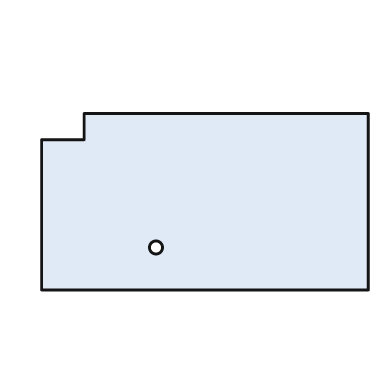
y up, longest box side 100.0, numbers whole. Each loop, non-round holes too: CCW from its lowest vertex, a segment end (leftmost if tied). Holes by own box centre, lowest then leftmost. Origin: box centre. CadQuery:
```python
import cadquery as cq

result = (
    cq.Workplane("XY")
    .moveTo(-50.0, -27.0)
    .lineTo(50.0, -27.0)
    .lineTo(50.0, 27.0)
    .lineTo(-37.0, 27.0)
    .lineTo(-37.0, 19.0)
    .lineTo(-50.0, 19.0)
    .close()
    .moveTo(-15.0, -14.0)
    .circle(2.0)
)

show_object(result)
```